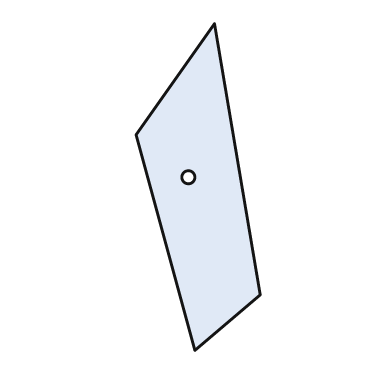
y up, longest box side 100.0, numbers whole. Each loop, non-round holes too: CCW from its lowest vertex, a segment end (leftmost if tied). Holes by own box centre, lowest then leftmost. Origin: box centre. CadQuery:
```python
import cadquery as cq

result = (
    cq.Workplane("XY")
    .moveTo(-1.0, -50.0)
    .lineTo(19.0, -33.0)
    .lineTo(5.0, 50.0)
    .lineTo(-19.0, 16.0)
    .close()
    .moveTo(-3.0, 3.0)
    .circle(2.0)
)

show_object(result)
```